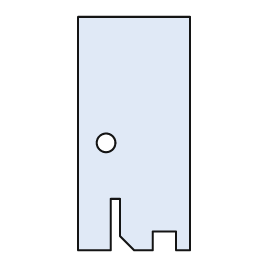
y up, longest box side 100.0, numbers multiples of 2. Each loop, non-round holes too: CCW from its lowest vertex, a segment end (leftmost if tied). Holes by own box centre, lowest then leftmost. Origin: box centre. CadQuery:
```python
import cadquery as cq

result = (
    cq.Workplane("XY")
    .moveTo(-24.0, -50.0)
    .lineTo(-10.0, -50.0)
    .lineTo(-10.0, -28.0)
    .lineTo(-6.0, -28.0)
    .lineTo(-6.0, -44.0)
    .lineTo(0.0, -50.0)
    .lineTo(8.0, -50.0)
    .lineTo(8.0, -42.0)
    .lineTo(18.0, -42.0)
    .lineTo(18.0, -50.0)
    .lineTo(24.0, -50.0)
    .lineTo(24.0, 50.0)
    .lineTo(-24.0, 50.0)
    .close()
    .moveTo(-12.0, -4.0)
    .circle(4.0)
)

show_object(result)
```